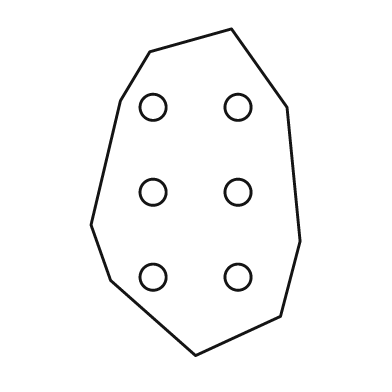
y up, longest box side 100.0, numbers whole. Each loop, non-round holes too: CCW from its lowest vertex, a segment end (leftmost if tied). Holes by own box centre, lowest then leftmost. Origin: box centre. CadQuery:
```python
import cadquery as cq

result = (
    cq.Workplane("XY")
    .moveTo(0.0, -50.0)
    .lineTo(26.0, -38.0)
    .lineTo(32.0, -15.0)
    .lineTo(28.0, 26.0)
    .lineTo(11.0, 50.0)
    .lineTo(-14.0, 43.0)
    .lineTo(-23.0, 28.0)
    .lineTo(-32.0, -10.0)
    .lineTo(-26.0, -27.0)
    .close()
    .moveTo(-13.0, -26.0)
    .circle(4.0)
    .moveTo(13.0, -26.0)
    .circle(4.0)
    .moveTo(-13.0, 0.0)
    .circle(4.0)
    .moveTo(13.0, 0.0)
    .circle(4.0)
    .moveTo(-13.0, 26.0)
    .circle(4.0)
    .moveTo(13.0, 26.0)
    .circle(4.0)
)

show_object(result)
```